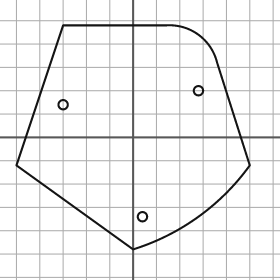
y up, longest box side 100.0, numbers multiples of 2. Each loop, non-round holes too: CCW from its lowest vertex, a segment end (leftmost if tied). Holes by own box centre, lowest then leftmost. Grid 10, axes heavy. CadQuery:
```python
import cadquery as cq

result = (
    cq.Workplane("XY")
    .moveTo(0.0, -48.0)
    .threePointArc((28.0, -34.0), (50.0, -12.0))
    .lineTo(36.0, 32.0)
    .threePointArc((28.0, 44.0), (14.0, 48.0))
    .lineTo(-30.0, 48.0)
    .lineTo(-50.0, -12.0)
    .close()
    .moveTo(4.0, -34.0)
    .circle(2.0)
    .moveTo(-30.0, 14.0)
    .circle(2.0)
    .moveTo(28.0, 20.0)
    .circle(2.0)
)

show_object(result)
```